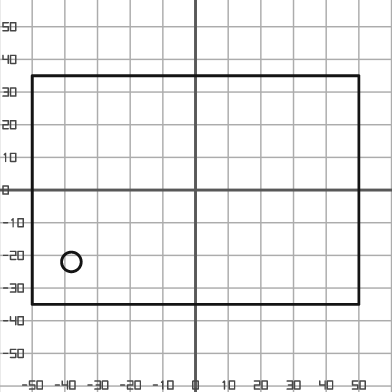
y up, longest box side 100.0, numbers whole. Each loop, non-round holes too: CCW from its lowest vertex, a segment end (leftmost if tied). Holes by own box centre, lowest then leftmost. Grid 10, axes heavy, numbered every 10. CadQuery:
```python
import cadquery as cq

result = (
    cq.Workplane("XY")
    .moveTo(-50.0, -35.0)
    .lineTo(50.0, -35.0)
    .lineTo(50.0, 35.0)
    .lineTo(-50.0, 35.0)
    .close()
    .moveTo(-38.0, -22.0)
    .circle(3.0)
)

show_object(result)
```